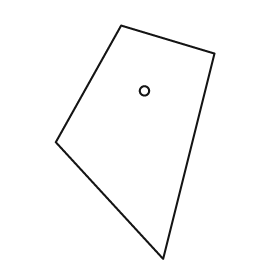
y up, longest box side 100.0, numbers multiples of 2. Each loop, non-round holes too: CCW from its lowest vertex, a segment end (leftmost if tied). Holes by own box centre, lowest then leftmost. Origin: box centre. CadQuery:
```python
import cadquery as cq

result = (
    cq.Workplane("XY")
    .moveTo(12.0, -50.0)
    .lineTo(34.0, 38.0)
    .lineTo(-6.0, 50.0)
    .lineTo(-34.0, 0.0)
    .close()
    .moveTo(4.0, 22.0)
    .circle(2.0)
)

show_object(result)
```